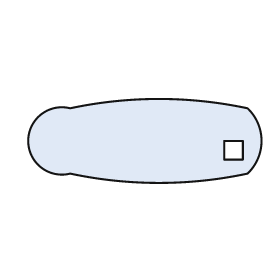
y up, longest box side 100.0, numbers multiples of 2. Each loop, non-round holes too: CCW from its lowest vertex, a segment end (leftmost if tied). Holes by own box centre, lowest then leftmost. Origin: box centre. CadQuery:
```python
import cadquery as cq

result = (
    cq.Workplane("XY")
    .moveTo(-32.0, -14.0)
    .threePointArc((6.0, -18.0), (44.0, -14.0))
    .threePointArc((50.0, 0.0), (44.0, 14.0))
    .threePointArc((6.0, 18.0), (-32.0, 14.0))
    .threePointArc((-50.0, 0.0), (-32.0, -14.0))
    .close()
    .moveTo(34.0, -8.0)
    .lineTo(42.0, -8.0)
    .lineTo(42.0, 0.0)
    .lineTo(34.0, 0.0)
    .close()
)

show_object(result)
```